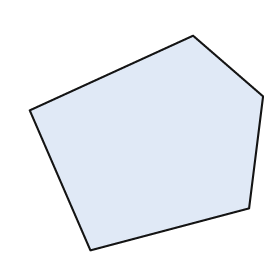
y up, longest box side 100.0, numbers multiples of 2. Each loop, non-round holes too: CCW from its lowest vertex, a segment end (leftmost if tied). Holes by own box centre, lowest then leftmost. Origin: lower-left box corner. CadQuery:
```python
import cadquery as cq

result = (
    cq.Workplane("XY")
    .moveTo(26.0, 0.0)
    .lineTo(94.0, 18.0)
    .lineTo(100.0, 66.0)
    .lineTo(70.0, 92.0)
    .lineTo(0.0, 60.0)
    .close()
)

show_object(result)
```